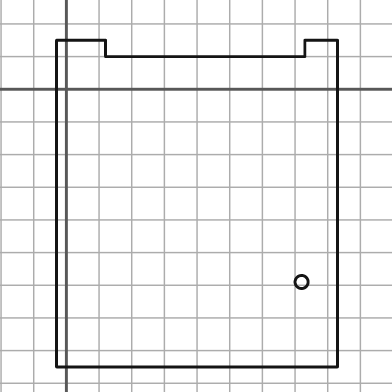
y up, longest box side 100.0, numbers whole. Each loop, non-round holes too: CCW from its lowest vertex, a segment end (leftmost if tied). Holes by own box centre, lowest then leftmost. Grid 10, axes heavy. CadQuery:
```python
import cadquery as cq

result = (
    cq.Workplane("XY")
    .moveTo(-3.0, -85.0)
    .lineTo(83.0, -85.0)
    .lineTo(83.0, 15.0)
    .lineTo(73.0, 15.0)
    .lineTo(73.0, 10.0)
    .lineTo(12.0, 10.0)
    .lineTo(12.0, 15.0)
    .lineTo(-3.0, 15.0)
    .close()
    .moveTo(72.0, -59.0)
    .circle(2.0)
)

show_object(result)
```